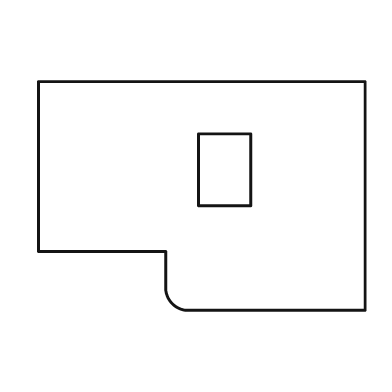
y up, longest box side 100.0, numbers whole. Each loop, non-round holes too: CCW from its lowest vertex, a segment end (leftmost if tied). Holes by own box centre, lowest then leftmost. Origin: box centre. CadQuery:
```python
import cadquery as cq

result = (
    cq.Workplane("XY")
    .moveTo(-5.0, -35.0)
    .lineTo(50.0, -35.0)
    .lineTo(50.0, 35.0)
    .lineTo(-50.0, 35.0)
    .lineTo(-50.0, -17.0)
    .lineTo(-11.0, -17.0)
    .lineTo(-11.0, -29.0)
    .threePointArc((-9.0, -33.0), (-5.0, -35.0))
    .close()
    .moveTo(-1.0, -3.0)
    .lineTo(15.0, -3.0)
    .lineTo(15.0, 19.0)
    .lineTo(-1.0, 19.0)
    .close()
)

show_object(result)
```